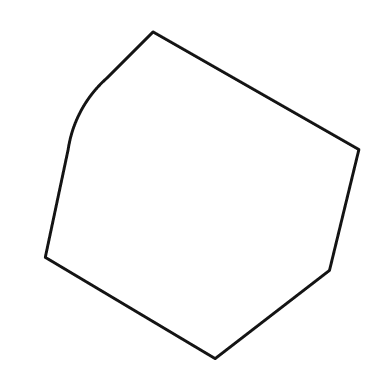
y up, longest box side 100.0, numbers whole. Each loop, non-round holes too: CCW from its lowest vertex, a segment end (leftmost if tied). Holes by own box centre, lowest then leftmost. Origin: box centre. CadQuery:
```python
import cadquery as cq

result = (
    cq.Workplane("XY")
    .moveTo(4.0, -50.0)
    .lineTo(39.0, -23.0)
    .lineTo(48.0, 14.0)
    .lineTo(-15.0, 50.0)
    .lineTo(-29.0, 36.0)
    .threePointArc((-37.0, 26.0), (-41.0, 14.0))
    .lineTo(-48.0, -19.0)
    .close()
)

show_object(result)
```